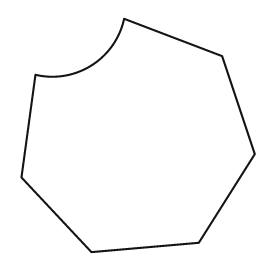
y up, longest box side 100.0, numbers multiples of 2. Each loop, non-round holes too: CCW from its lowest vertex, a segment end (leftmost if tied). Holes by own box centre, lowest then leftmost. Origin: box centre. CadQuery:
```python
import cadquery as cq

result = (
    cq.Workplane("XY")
    .moveTo(-20.0, -50.0)
    .lineTo(26.0, -46.0)
    .lineTo(50.0, -8.0)
    .lineTo(36.0, 34.0)
    .lineTo(-6.0, 50.0)
    .threePointArc((-20.0, 30.0), (-44.0, 26.0))
    .lineTo(-50.0, -18.0)
    .close()
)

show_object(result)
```